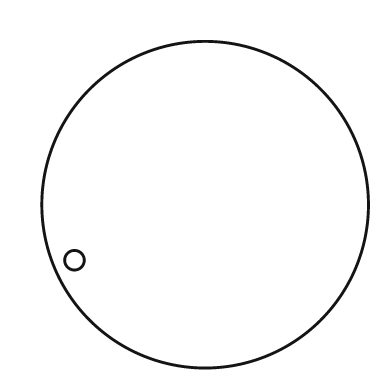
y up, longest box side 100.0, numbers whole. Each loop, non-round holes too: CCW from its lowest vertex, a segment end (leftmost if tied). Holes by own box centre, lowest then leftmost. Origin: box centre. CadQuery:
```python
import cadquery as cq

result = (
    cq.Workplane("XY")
    .moveTo(0.0, 0.0)
    .circle(50.0)
    .moveTo(-40.0, -17.0)
    .circle(3.0)
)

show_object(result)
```